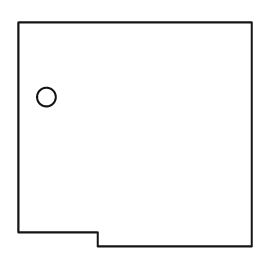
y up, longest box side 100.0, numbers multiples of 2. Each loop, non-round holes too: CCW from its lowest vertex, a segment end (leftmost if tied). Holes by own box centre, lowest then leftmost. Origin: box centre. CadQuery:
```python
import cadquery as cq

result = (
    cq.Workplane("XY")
    .moveTo(-16.0, -48.0)
    .lineTo(50.0, -48.0)
    .lineTo(50.0, 48.0)
    .lineTo(-50.0, 48.0)
    .lineTo(-50.0, -42.0)
    .lineTo(-16.0, -42.0)
    .close()
    .moveTo(-38.0, 16.0)
    .circle(4.0)
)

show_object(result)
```